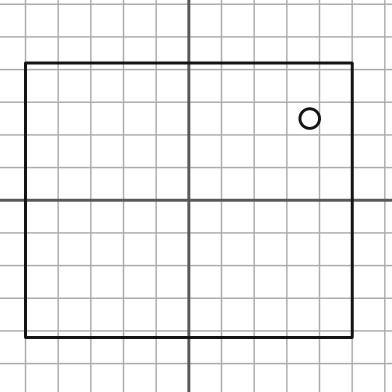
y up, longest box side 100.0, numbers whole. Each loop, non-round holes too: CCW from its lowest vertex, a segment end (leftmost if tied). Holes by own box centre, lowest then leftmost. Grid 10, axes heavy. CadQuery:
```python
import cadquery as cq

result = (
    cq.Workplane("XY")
    .moveTo(-50.0, -42.0)
    .lineTo(50.0, -42.0)
    .lineTo(50.0, 42.0)
    .lineTo(-50.0, 42.0)
    .close()
    .moveTo(37.0, 25.0)
    .circle(3.0)
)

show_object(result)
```